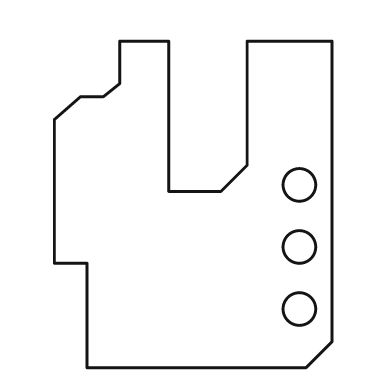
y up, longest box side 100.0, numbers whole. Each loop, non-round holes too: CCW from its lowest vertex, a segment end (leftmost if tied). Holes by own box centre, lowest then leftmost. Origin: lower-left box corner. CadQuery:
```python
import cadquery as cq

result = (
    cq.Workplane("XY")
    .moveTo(10.0, 0.0)
    .lineTo(77.0, 0.0)
    .lineTo(85.0, 8.0)
    .lineTo(85.0, 100.0)
    .lineTo(59.0, 100.0)
    .lineTo(59.0, 62.0)
    .lineTo(51.0, 54.0)
    .lineTo(35.0, 54.0)
    .lineTo(35.0, 100.0)
    .lineTo(20.0, 100.0)
    .lineTo(20.0, 87.0)
    .lineTo(15.0, 83.0)
    .lineTo(8.0, 83.0)
    .lineTo(0.0, 76.0)
    .lineTo(0.0, 32.0)
    .lineTo(10.0, 32.0)
    .close()
    .moveTo(75.0, 18.0)
    .circle(5.0)
    .moveTo(75.0, 37.0)
    .circle(5.0)
    .moveTo(75.0, 56.0)
    .circle(5.0)
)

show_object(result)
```